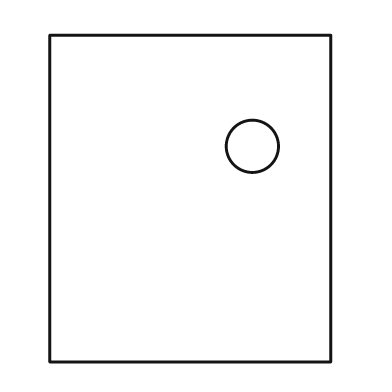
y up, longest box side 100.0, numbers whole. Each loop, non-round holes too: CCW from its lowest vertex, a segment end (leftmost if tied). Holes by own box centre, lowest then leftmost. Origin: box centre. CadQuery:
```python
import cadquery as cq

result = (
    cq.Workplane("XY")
    .moveTo(-43.0, -50.0)
    .lineTo(43.0, -50.0)
    .lineTo(43.0, 50.0)
    .lineTo(-43.0, 50.0)
    .close()
    .moveTo(19.0, 16.0)
    .circle(8.0)
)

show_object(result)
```